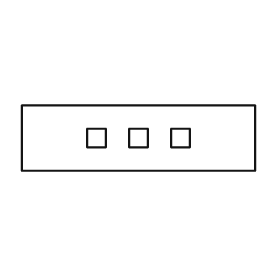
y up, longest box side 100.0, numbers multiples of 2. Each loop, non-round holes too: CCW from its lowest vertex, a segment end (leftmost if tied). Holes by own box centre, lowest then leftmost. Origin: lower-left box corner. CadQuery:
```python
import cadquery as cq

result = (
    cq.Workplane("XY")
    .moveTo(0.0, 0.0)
    .lineTo(100.0, 0.0)
    .lineTo(100.0, 28.0)
    .lineTo(0.0, 28.0)
    .close()
    .moveTo(28.0, 10.0)
    .lineTo(36.0, 10.0)
    .lineTo(36.0, 18.0)
    .lineTo(28.0, 18.0)
    .close()
    .moveTo(46.0, 10.0)
    .lineTo(54.0, 10.0)
    .lineTo(54.0, 18.0)
    .lineTo(46.0, 18.0)
    .close()
    .moveTo(64.0, 10.0)
    .lineTo(72.0, 10.0)
    .lineTo(72.0, 18.0)
    .lineTo(64.0, 18.0)
    .close()
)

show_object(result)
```